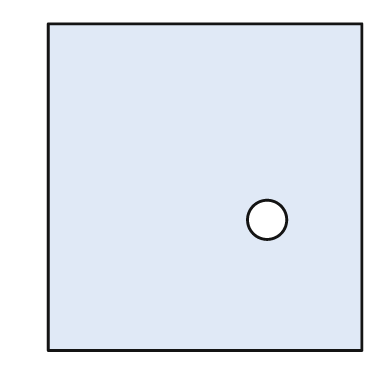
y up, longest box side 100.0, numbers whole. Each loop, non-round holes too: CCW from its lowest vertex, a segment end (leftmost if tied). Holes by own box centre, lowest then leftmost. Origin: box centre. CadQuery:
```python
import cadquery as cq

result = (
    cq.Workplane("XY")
    .moveTo(-48.0, -50.0)
    .lineTo(48.0, -50.0)
    .lineTo(48.0, 50.0)
    .lineTo(-48.0, 50.0)
    .close()
    .moveTo(19.0, -10.0)
    .circle(6.0)
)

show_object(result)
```